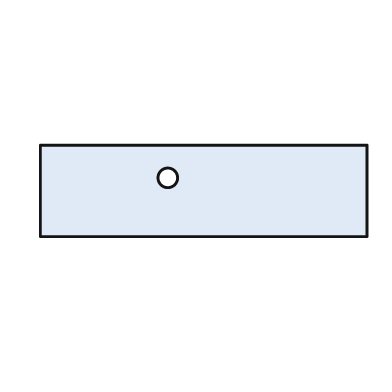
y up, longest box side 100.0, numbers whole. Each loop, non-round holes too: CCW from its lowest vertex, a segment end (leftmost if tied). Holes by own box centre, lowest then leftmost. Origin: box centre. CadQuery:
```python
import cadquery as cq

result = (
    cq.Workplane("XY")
    .moveTo(-50.0, -14.0)
    .lineTo(50.0, -14.0)
    .lineTo(50.0, 14.0)
    .lineTo(-50.0, 14.0)
    .close()
    .moveTo(-11.0, 4.0)
    .circle(3.0)
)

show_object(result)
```